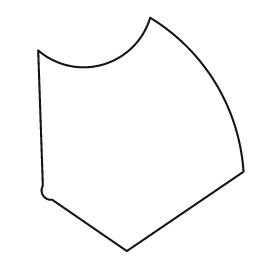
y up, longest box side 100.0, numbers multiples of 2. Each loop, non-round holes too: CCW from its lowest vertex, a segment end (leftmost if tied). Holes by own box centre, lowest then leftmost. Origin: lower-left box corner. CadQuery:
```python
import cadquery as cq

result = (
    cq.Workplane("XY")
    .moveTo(38.0, 0.0)
    .lineTo(88.0, 34.0)
    .threePointArc((76.0, 72.0), (48.0, 100.0))
    .threePointArc((28.0, 80.0), (0.0, 86.0))
    .lineTo(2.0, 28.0)
    .threePointArc((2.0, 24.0), (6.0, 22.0))
    .close()
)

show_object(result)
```